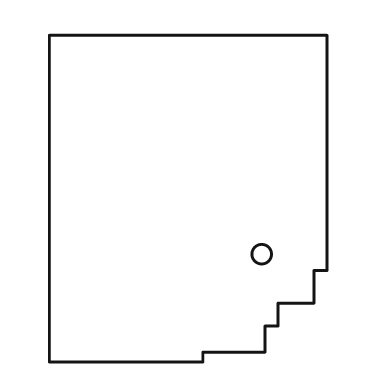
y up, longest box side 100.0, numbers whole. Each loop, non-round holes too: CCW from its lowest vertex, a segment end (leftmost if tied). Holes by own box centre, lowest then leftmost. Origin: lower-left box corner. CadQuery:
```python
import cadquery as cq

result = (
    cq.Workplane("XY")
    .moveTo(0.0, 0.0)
    .lineTo(47.0, 0.0)
    .lineTo(47.0, 3.0)
    .lineTo(66.0, 3.0)
    .lineTo(66.0, 11.0)
    .lineTo(70.0, 11.0)
    .lineTo(70.0, 18.0)
    .lineTo(81.0, 18.0)
    .lineTo(81.0, 28.0)
    .lineTo(85.0, 28.0)
    .lineTo(85.0, 100.0)
    .lineTo(0.0, 100.0)
    .close()
    .moveTo(65.0, 33.0)
    .circle(3.0)
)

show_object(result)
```